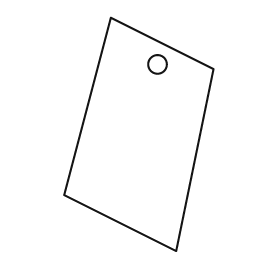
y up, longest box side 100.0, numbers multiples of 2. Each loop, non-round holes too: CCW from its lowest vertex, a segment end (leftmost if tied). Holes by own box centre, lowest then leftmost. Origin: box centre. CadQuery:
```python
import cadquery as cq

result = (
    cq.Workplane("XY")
    .moveTo(16.0, -50.0)
    .lineTo(32.0, 28.0)
    .lineTo(-12.0, 50.0)
    .lineTo(-32.0, -26.0)
    .close()
    .moveTo(8.0, 30.0)
    .circle(4.0)
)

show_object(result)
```